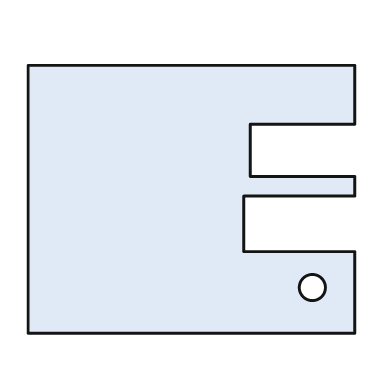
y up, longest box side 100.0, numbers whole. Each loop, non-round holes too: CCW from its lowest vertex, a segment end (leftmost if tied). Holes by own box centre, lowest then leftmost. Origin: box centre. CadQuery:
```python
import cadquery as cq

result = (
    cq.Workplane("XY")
    .moveTo(-50.0, -41.0)
    .lineTo(50.0, -41.0)
    .lineTo(50.0, -16.0)
    .lineTo(16.0, -16.0)
    .lineTo(16.0, 1.0)
    .lineTo(50.0, 1.0)
    .lineTo(50.0, 7.0)
    .lineTo(18.0, 7.0)
    .lineTo(18.0, 23.0)
    .lineTo(50.0, 23.0)
    .lineTo(50.0, 41.0)
    .lineTo(-50.0, 41.0)
    .close()
    .moveTo(37.0, -27.0)
    .circle(4.0)
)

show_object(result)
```